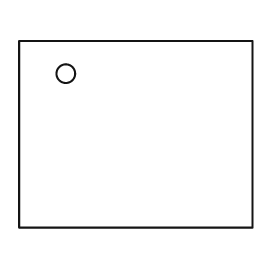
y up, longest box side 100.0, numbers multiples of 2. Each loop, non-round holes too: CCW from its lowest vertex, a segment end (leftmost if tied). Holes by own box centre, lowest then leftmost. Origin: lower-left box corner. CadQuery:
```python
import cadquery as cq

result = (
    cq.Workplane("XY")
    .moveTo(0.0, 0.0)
    .lineTo(100.0, 0.0)
    .lineTo(100.0, 80.0)
    .lineTo(0.0, 80.0)
    .close()
    .moveTo(20.0, 66.0)
    .circle(4.0)
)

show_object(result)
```